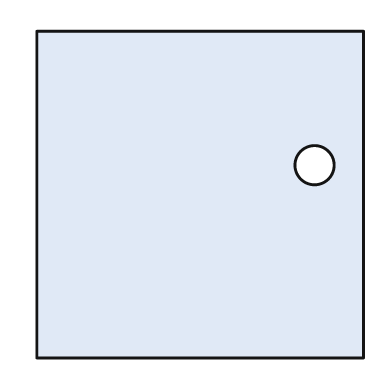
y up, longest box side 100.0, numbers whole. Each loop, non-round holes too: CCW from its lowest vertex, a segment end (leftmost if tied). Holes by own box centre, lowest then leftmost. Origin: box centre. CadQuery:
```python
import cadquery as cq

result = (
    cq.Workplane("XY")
    .moveTo(-50.0, -50.0)
    .lineTo(50.0, -50.0)
    .lineTo(50.0, 50.0)
    .lineTo(-50.0, 50.0)
    .close()
    .moveTo(35.0, 9.0)
    .circle(6.0)
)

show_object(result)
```